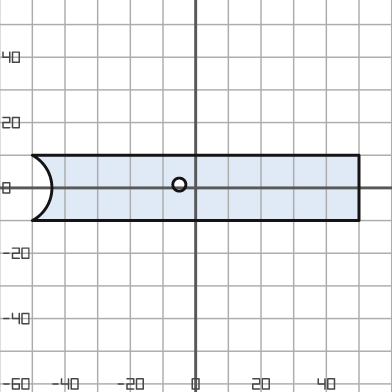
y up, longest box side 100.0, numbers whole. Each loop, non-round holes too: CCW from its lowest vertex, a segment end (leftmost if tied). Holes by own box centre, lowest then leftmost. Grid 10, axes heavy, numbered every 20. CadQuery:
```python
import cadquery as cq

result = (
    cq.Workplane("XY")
    .moveTo(-50.0, -10.0)
    .lineTo(50.0, -10.0)
    .lineTo(50.0, 10.0)
    .lineTo(-50.0, 10.0)
    .threePointArc((-44.0, 0.0), (-50.0, -10.0))
    .close()
    .moveTo(-5.0, 1.0)
    .circle(2.0)
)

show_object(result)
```